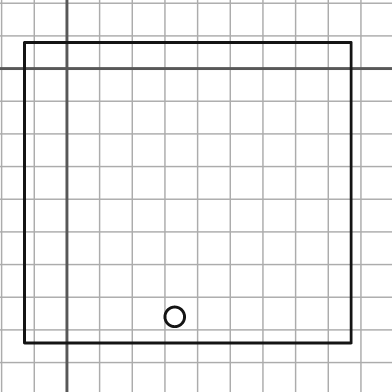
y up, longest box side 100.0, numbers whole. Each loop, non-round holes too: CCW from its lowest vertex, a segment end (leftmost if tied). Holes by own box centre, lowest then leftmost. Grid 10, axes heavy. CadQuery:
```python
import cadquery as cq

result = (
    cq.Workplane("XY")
    .moveTo(-13.0, -84.0)
    .lineTo(87.0, -84.0)
    .lineTo(87.0, 8.0)
    .lineTo(-13.0, 8.0)
    .close()
    .moveTo(33.0, -76.0)
    .circle(3.0)
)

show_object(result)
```